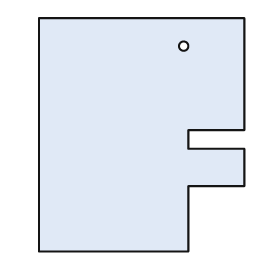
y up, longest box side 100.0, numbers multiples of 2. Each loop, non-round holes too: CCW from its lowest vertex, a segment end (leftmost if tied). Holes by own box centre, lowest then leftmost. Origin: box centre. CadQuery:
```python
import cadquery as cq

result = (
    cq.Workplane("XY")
    .moveTo(-44.0, -50.0)
    .lineTo(20.0, -50.0)
    .lineTo(20.0, -22.0)
    .lineTo(44.0, -22.0)
    .lineTo(44.0, -6.0)
    .lineTo(20.0, -6.0)
    .lineTo(20.0, 2.0)
    .lineTo(44.0, 2.0)
    .lineTo(44.0, 50.0)
    .lineTo(-44.0, 50.0)
    .close()
    .moveTo(18.0, 38.0)
    .circle(2.0)
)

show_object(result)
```